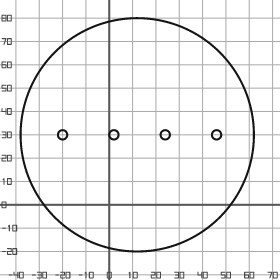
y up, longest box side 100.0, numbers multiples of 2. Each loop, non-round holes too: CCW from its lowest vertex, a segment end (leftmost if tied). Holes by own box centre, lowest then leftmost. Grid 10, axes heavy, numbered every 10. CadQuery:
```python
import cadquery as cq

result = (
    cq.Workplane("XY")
    .moveTo(12.0, 30.0)
    .circle(50.0)
    .moveTo(-20.0, 30.0)
    .circle(2.0)
    .moveTo(2.0, 30.0)
    .circle(2.0)
    .moveTo(24.0, 30.0)
    .circle(2.0)
    .moveTo(46.0, 30.0)
    .circle(2.0)
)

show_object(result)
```